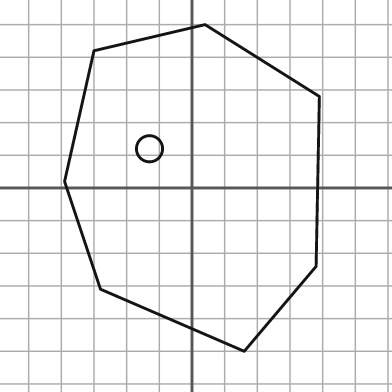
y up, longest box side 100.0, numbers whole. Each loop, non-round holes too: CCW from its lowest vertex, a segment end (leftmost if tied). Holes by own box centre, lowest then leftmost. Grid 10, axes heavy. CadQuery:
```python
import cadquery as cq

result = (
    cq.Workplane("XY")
    .moveTo(16.0, -50.0)
    .lineTo(38.0, -24.0)
    .lineTo(39.0, 28.0)
    .lineTo(4.0, 50.0)
    .lineTo(-30.0, 42.0)
    .lineTo(-39.0, 2.0)
    .lineTo(-28.0, -31.0)
    .close()
    .moveTo(-13.0, 12.0)
    .circle(4.0)
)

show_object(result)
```